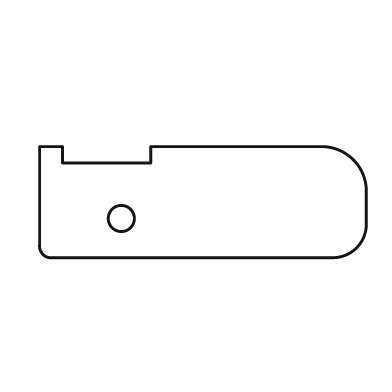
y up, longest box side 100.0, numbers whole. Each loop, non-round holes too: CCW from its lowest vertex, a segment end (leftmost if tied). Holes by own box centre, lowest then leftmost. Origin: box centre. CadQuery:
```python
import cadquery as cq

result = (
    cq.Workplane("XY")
    .moveTo(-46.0, -17.0)
    .lineTo(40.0, -17.0)
    .threePointArc((47.0, -14.0), (50.0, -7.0))
    .lineTo(50.0, 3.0)
    .threePointArc((46.0, 13.0), (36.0, 17.0))
    .lineTo(-16.0, 17.0)
    .lineTo(-16.0, 12.0)
    .lineTo(-43.0, 12.0)
    .lineTo(-43.0, 17.0)
    .lineTo(-50.0, 17.0)
    .lineTo(-50.0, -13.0)
    .threePointArc((-49.0, -16.0), (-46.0, -17.0))
    .close()
    .moveTo(-25.0, -5.0)
    .circle(4.0)
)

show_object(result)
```